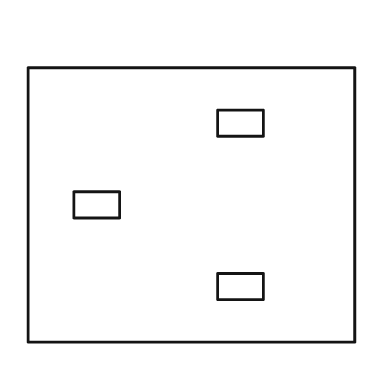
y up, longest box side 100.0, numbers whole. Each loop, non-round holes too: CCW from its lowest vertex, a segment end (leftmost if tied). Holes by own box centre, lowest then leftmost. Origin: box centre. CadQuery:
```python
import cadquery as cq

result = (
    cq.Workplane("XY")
    .moveTo(-50.0, -42.0)
    .lineTo(50.0, -42.0)
    .lineTo(50.0, 42.0)
    .lineTo(-50.0, 42.0)
    .close()
    .moveTo(8.0, -29.0)
    .lineTo(22.0, -29.0)
    .lineTo(22.0, -21.0)
    .lineTo(8.0, -21.0)
    .close()
    .moveTo(-36.0, -4.0)
    .lineTo(-22.0, -4.0)
    .lineTo(-22.0, 4.0)
    .lineTo(-36.0, 4.0)
    .close()
    .moveTo(8.0, 21.0)
    .lineTo(22.0, 21.0)
    .lineTo(22.0, 29.0)
    .lineTo(8.0, 29.0)
    .close()
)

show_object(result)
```